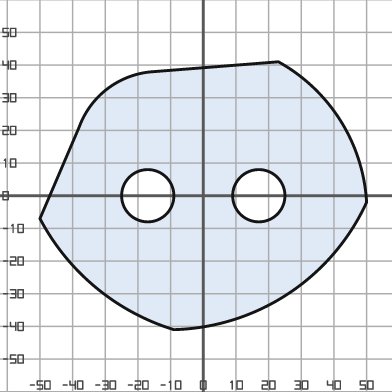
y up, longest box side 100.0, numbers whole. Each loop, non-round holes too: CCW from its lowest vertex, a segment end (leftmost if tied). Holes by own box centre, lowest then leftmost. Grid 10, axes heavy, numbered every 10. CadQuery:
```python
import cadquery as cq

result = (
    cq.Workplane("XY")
    .moveTo(-9.0, -41.0)
    .threePointArc((26.0, -30.0), (50.0, -2.0))
    .threePointArc((42.0, 23.0), (23.0, 41.0))
    .lineTo(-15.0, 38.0)
    .threePointArc((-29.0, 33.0), (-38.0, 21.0))
    .lineTo(-50.0, -7.0)
    .threePointArc((-33.0, -28.0), (-9.0, -41.0))
    .close()
    .moveTo(-17.0, 0.0)
    .circle(8.0)
    .moveTo(17.0, 0.0)
    .circle(8.0)
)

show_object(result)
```